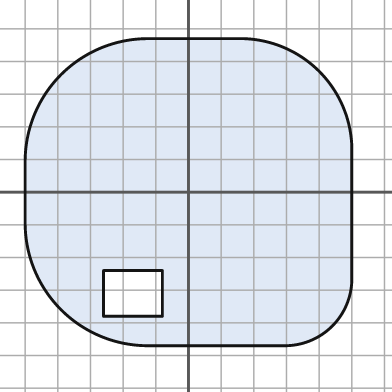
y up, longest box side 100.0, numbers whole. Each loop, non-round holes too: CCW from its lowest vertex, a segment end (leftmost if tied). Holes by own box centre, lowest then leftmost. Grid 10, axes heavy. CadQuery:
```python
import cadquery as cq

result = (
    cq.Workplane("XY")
    .moveTo(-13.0, -47.0)
    .lineTo(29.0, -47.0)
    .threePointArc((44.0, -41.0), (50.0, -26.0))
    .lineTo(50.0, 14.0)
    .threePointArc((40.0, 37.0), (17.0, 47.0))
    .lineTo(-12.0, 47.0)
    .threePointArc((-39.0, 36.0), (-50.0, 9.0))
    .lineTo(-50.0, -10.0)
    .threePointArc((-39.0, -36.0), (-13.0, -47.0))
    .close()
    .moveTo(-26.0, -38.0)
    .lineTo(-8.0, -38.0)
    .lineTo(-8.0, -24.0)
    .lineTo(-26.0, -24.0)
    .close()
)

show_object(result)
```